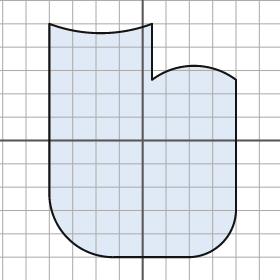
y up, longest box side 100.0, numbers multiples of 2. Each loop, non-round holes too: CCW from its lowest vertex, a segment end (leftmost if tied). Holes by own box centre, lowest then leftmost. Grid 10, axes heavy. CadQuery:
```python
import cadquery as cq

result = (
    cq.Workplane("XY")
    .moveTo(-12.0, -50.0)
    .lineTo(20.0, -50.0)
    .threePointArc((34.0, -44.0), (40.0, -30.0))
    .lineTo(40.0, 26.0)
    .threePointArc((22.0, 32.0), (4.0, 26.0))
    .lineTo(4.0, 50.0)
    .threePointArc((-18.0, 46.0), (-40.0, 50.0))
    .lineTo(-40.0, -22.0)
    .threePointArc((-32.0, -42.0), (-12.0, -50.0))
    .close()
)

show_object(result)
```